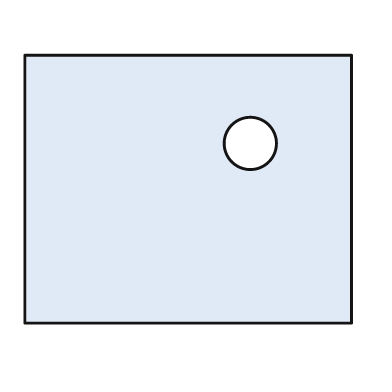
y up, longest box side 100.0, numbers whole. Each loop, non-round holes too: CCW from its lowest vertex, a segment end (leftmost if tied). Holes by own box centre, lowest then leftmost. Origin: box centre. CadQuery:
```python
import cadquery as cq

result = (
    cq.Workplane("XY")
    .moveTo(-50.0, -41.0)
    .lineTo(50.0, -41.0)
    .lineTo(50.0, 41.0)
    .lineTo(-50.0, 41.0)
    .close()
    .moveTo(19.0, 14.0)
    .circle(8.0)
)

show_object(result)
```